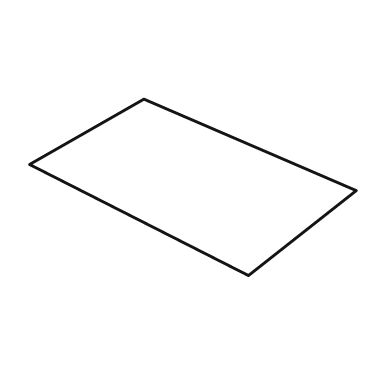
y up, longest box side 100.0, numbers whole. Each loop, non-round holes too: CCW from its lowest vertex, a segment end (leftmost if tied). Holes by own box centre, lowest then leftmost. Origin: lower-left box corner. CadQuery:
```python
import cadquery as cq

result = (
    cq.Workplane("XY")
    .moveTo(67.0, 0.0)
    .lineTo(100.0, 26.0)
    .lineTo(35.0, 54.0)
    .lineTo(0.0, 34.0)
    .close()
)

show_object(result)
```